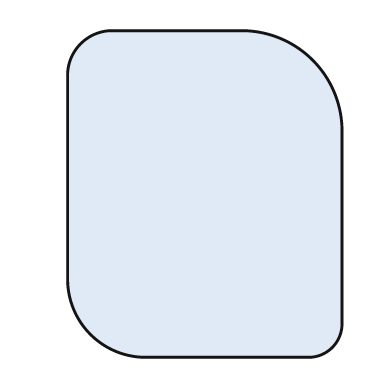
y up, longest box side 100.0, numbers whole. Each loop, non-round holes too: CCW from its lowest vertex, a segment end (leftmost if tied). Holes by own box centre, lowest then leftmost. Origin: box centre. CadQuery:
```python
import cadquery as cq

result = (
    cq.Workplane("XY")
    .moveTo(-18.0, -50.0)
    .lineTo(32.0, -50.0)
    .threePointArc((39.0, -47.0), (42.0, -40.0))
    .lineTo(42.0, 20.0)
    .threePointArc((33.0, 41.0), (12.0, 50.0))
    .lineTo(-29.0, 50.0)
    .threePointArc((-38.0, 46.0), (-42.0, 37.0))
    .lineTo(-42.0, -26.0)
    .threePointArc((-35.0, -43.0), (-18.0, -50.0))
    .close()
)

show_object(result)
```